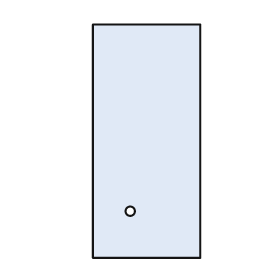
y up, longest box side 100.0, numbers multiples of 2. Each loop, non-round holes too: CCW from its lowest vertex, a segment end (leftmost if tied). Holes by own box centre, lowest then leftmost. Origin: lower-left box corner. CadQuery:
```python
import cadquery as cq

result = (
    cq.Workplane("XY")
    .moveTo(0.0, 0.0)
    .lineTo(46.0, 0.0)
    .lineTo(46.0, 100.0)
    .lineTo(0.0, 100.0)
    .close()
    .moveTo(16.0, 20.0)
    .circle(2.0)
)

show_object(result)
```